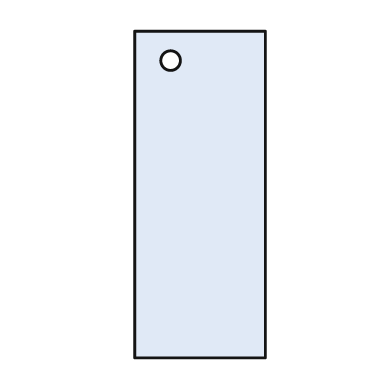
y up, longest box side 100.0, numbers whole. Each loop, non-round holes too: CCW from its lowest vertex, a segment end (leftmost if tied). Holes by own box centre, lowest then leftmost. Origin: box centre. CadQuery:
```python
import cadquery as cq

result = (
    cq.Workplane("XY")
    .moveTo(-20.0, -50.0)
    .lineTo(20.0, -50.0)
    .lineTo(20.0, 50.0)
    .lineTo(-20.0, 50.0)
    .close()
    .moveTo(-9.0, 41.0)
    .circle(3.0)
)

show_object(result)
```